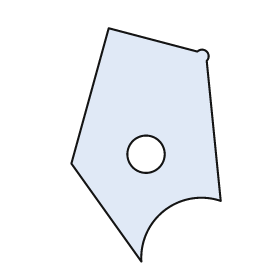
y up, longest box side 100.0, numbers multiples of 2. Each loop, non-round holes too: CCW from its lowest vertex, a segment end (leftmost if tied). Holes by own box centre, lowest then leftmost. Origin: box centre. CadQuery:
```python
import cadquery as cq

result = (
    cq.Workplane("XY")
    .moveTo(-2.0, -50.0)
    .threePointArc((8.0, -28.0), (32.0, -24.0))
    .lineTo(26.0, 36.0)
    .threePointArc((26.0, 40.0), (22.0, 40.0))
    .lineTo(-16.0, 50.0)
    .lineTo(-32.0, -8.0)
    .close()
    .moveTo(0.0, -4.0)
    .circle(8.0)
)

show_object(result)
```